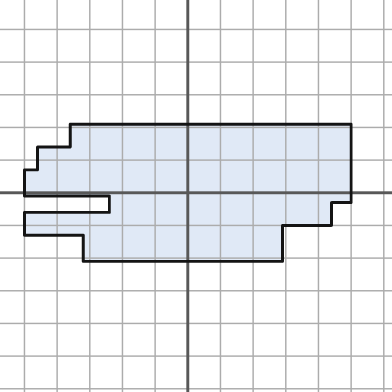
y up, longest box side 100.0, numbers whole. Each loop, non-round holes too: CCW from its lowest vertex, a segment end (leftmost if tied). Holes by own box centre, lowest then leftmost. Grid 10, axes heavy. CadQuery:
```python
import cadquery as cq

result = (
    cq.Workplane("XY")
    .moveTo(-32.0, -21.0)
    .lineTo(29.0, -21.0)
    .lineTo(29.0, -10.0)
    .lineTo(44.0, -10.0)
    .lineTo(44.0, -3.0)
    .lineTo(50.0, -3.0)
    .lineTo(50.0, 21.0)
    .lineTo(-36.0, 21.0)
    .lineTo(-36.0, 14.0)
    .lineTo(-46.0, 14.0)
    .lineTo(-46.0, 7.0)
    .lineTo(-50.0, 7.0)
    .lineTo(-50.0, -1.0)
    .lineTo(-24.0, -1.0)
    .lineTo(-24.0, -6.0)
    .lineTo(-50.0, -6.0)
    .lineTo(-50.0, -13.0)
    .lineTo(-32.0, -13.0)
    .close()
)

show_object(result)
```